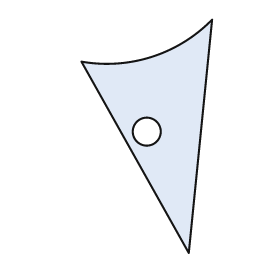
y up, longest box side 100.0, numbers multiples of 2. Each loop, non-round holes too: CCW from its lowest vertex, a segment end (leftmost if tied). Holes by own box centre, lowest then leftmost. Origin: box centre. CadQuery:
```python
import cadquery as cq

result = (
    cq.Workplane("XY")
    .moveTo(18.0, -50.0)
    .lineTo(28.0, 50.0)
    .threePointArc((2.0, 34.0), (-28.0, 32.0))
    .close()
    .moveTo(0.0, 2.0)
    .circle(6.0)
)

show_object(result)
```